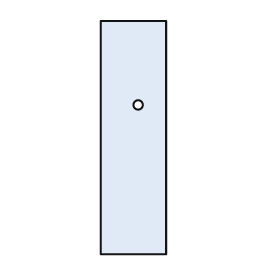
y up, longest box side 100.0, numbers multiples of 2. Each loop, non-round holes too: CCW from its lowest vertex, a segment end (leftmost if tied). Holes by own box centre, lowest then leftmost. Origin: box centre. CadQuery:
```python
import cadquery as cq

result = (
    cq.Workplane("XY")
    .moveTo(-14.0, -50.0)
    .lineTo(14.0, -50.0)
    .lineTo(14.0, 50.0)
    .lineTo(-14.0, 50.0)
    .close()
    .moveTo(2.0, 14.0)
    .circle(2.0)
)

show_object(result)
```